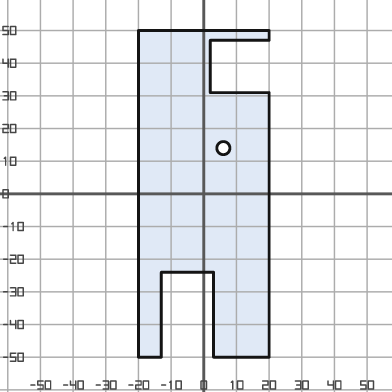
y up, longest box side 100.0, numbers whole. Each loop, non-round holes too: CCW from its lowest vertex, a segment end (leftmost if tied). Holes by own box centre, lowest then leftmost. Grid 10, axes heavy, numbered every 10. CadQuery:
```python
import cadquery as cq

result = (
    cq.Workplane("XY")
    .moveTo(-20.0, -50.0)
    .lineTo(-13.0, -50.0)
    .lineTo(-13.0, -24.0)
    .lineTo(3.0, -24.0)
    .lineTo(3.0, -50.0)
    .lineTo(20.0, -50.0)
    .lineTo(20.0, 31.0)
    .lineTo(2.0, 31.0)
    .lineTo(2.0, 47.0)
    .lineTo(20.0, 47.0)
    .lineTo(20.0, 50.0)
    .lineTo(-20.0, 50.0)
    .close()
    .moveTo(6.0, 14.0)
    .circle(2.0)
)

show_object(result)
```